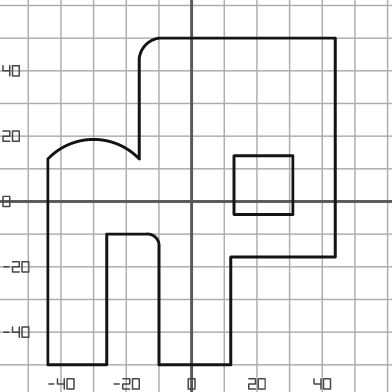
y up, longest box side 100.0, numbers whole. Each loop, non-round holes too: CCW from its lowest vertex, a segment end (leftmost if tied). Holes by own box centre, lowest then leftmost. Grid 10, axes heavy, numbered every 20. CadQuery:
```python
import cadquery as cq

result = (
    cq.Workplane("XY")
    .moveTo(-44.0, -50.0)
    .lineTo(-26.0, -50.0)
    .lineTo(-26.0, -10.0)
    .lineTo(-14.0, -10.0)
    .threePointArc((-11.0, -11.0), (-10.0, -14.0))
    .lineTo(-10.0, -50.0)
    .lineTo(12.0, -50.0)
    .lineTo(12.0, -17.0)
    .lineTo(44.0, -17.0)
    .lineTo(44.0, 50.0)
    .lineTo(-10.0, 50.0)
    .threePointArc((-14.0, 48.0), (-16.0, 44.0))
    .lineTo(-16.0, 13.0)
    .threePointArc((-30.0, 19.0), (-44.0, 13.0))
    .close()
    .moveTo(13.0, -4.0)
    .lineTo(31.0, -4.0)
    .lineTo(31.0, 14.0)
    .lineTo(13.0, 14.0)
    .close()
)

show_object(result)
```